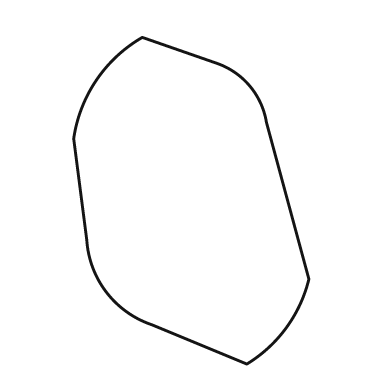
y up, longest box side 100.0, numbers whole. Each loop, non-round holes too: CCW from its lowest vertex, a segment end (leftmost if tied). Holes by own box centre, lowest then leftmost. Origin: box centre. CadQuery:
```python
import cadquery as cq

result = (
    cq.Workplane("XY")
    .moveTo(17.0, -50.0)
    .threePointArc((29.0, -39.0), (36.0, -24.0))
    .lineTo(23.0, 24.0)
    .threePointArc((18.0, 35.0), (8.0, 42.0))
    .lineTo(-15.0, 50.0)
    .threePointArc((-29.0, 37.0), (-36.0, 19.0))
    .lineTo(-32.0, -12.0)
    .threePointArc((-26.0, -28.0), (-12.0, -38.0))
    .close()
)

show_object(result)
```